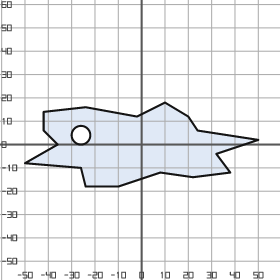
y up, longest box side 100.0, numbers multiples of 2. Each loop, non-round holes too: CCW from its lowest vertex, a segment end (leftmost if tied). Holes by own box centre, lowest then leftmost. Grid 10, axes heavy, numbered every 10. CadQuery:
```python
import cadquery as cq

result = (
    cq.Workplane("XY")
    .moveTo(-24.0, -18.0)
    .lineTo(-10.0, -18.0)
    .lineTo(8.0, -12.0)
    .lineTo(22.0, -14.0)
    .lineTo(38.0, -12.0)
    .lineTo(32.0, -4.0)
    .lineTo(50.0, 2.0)
    .lineTo(24.0, 6.0)
    .lineTo(20.0, 12.0)
    .lineTo(10.0, 18.0)
    .lineTo(-2.0, 12.0)
    .lineTo(-24.0, 16.0)
    .lineTo(-42.0, 14.0)
    .lineTo(-42.0, 6.0)
    .lineTo(-36.0, 0.0)
    .lineTo(-50.0, -8.0)
    .lineTo(-26.0, -10.0)
    .close()
    .moveTo(-26.0, 4.0)
    .circle(4.0)
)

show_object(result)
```